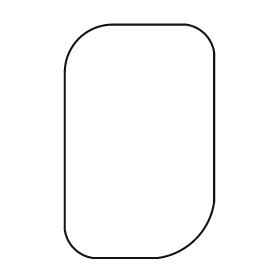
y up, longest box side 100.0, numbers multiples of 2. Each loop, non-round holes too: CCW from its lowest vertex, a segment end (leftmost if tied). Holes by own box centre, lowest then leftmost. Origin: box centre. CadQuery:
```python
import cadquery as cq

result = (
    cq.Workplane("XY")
    .moveTo(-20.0, -50.0)
    .lineTo(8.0, -50.0)
    .threePointArc((24.0, -42.0), (32.0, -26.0))
    .lineTo(32.0, 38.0)
    .threePointArc((28.0, 46.0), (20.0, 50.0))
    .lineTo(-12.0, 50.0)
    .threePointArc((-26.0, 44.0), (-32.0, 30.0))
    .lineTo(-32.0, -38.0)
    .threePointArc((-28.0, -46.0), (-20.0, -50.0))
    .close()
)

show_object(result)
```